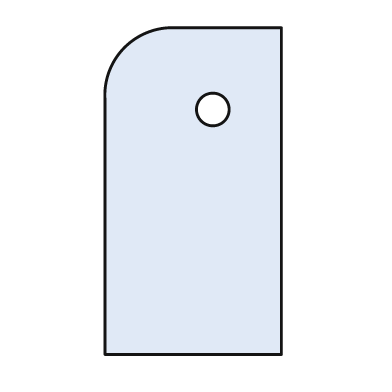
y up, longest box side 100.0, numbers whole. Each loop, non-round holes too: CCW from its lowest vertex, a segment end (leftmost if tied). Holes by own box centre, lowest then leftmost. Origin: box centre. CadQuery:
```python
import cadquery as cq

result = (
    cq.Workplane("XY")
    .moveTo(-27.0, -50.0)
    .lineTo(27.0, -50.0)
    .lineTo(27.0, 50.0)
    .lineTo(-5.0, 50.0)
    .threePointArc((-21.0, 44.0), (-27.0, 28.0))
    .close()
    .moveTo(6.0, 25.0)
    .circle(5.0)
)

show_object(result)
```